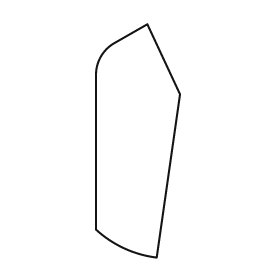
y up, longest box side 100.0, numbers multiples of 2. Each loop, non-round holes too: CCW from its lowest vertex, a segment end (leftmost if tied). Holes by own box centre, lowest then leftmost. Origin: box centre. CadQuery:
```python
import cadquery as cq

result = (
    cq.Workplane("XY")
    .moveTo(8.0, -50.0)
    .lineTo(18.0, 20.0)
    .lineTo(4.0, 50.0)
    .lineTo(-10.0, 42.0)
    .threePointArc((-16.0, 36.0), (-18.0, 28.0))
    .lineTo(-18.0, -38.0)
    .threePointArc((-6.0, -46.0), (8.0, -50.0))
    .close()
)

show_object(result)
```